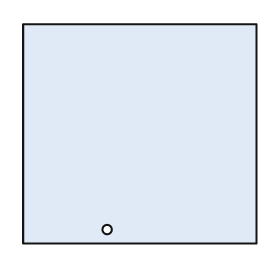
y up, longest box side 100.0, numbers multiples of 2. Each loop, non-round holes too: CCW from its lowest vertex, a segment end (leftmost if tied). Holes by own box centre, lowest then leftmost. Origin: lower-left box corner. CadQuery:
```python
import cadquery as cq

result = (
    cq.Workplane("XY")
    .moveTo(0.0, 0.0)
    .lineTo(100.0, 0.0)
    .lineTo(100.0, 94.0)
    .lineTo(0.0, 94.0)
    .close()
    .moveTo(36.0, 6.0)
    .circle(2.0)
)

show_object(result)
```